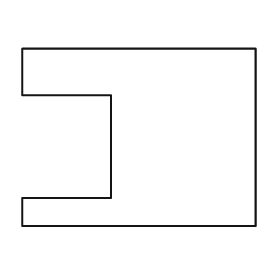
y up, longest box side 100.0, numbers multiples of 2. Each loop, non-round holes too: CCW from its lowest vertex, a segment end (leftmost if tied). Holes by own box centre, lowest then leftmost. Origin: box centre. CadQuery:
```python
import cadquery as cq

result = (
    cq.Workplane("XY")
    .moveTo(-50.0, -38.0)
    .lineTo(50.0, -38.0)
    .lineTo(50.0, 38.0)
    .lineTo(-50.0, 38.0)
    .lineTo(-50.0, 18.0)
    .lineTo(-12.0, 18.0)
    .lineTo(-12.0, -26.0)
    .lineTo(-50.0, -26.0)
    .close()
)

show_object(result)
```